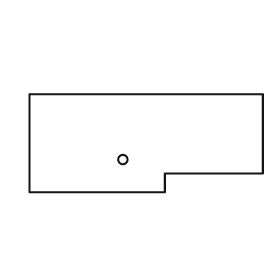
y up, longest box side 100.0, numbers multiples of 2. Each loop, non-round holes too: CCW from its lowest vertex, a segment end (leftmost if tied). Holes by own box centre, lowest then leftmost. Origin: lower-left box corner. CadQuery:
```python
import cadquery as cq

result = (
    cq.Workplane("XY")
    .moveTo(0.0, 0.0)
    .lineTo(58.0, 0.0)
    .lineTo(58.0, 8.0)
    .lineTo(100.0, 8.0)
    .lineTo(100.0, 42.0)
    .lineTo(0.0, 42.0)
    .close()
    .moveTo(40.0, 14.0)
    .circle(2.0)
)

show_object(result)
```